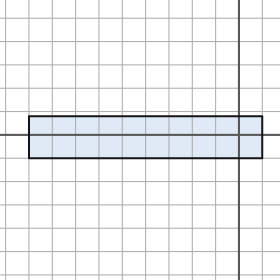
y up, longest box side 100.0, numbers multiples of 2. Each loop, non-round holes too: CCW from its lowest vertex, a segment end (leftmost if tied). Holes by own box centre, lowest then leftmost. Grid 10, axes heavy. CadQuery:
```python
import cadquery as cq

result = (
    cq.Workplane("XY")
    .moveTo(-90.0, -10.0)
    .lineTo(10.0, -10.0)
    .lineTo(10.0, 8.0)
    .lineTo(-90.0, 8.0)
    .close()
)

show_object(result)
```